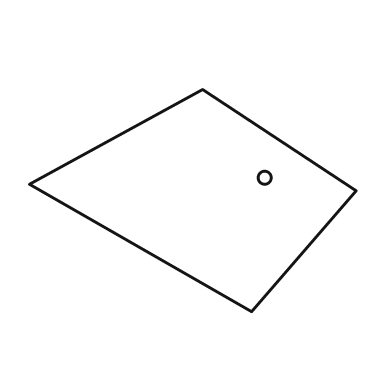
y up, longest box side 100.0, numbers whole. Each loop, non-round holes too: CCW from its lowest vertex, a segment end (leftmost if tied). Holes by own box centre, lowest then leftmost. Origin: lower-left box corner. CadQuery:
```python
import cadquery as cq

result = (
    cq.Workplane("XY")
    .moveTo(68.0, 0.0)
    .lineTo(100.0, 37.0)
    .lineTo(53.0, 68.0)
    .lineTo(0.0, 39.0)
    .close()
    .moveTo(72.0, 41.0)
    .circle(2.0)
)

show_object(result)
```